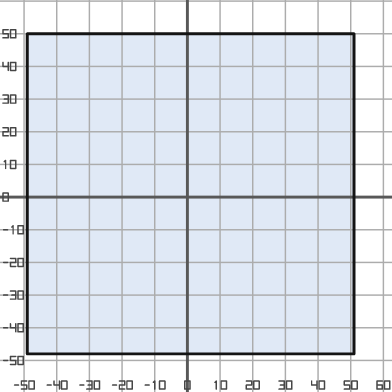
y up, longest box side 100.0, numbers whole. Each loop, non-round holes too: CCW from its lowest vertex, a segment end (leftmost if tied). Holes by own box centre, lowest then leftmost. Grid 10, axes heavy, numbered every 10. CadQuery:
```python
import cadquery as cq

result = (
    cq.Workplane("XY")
    .moveTo(-49.0, -48.0)
    .lineTo(51.0, -48.0)
    .lineTo(51.0, 50.0)
    .lineTo(-49.0, 50.0)
    .close()
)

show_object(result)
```